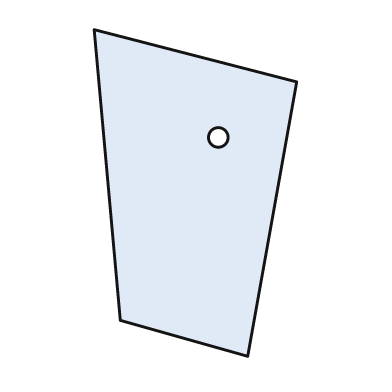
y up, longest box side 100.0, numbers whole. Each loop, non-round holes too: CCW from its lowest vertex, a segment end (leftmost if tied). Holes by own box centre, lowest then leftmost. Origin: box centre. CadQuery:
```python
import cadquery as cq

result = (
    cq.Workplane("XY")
    .moveTo(16.0, -50.0)
    .lineTo(31.0, 34.0)
    .lineTo(-31.0, 50.0)
    .lineTo(-23.0, -39.0)
    .close()
    .moveTo(7.0, 17.0)
    .circle(3.0)
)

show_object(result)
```